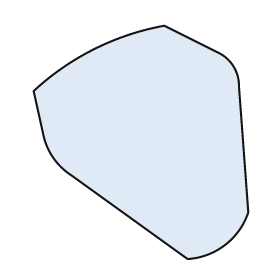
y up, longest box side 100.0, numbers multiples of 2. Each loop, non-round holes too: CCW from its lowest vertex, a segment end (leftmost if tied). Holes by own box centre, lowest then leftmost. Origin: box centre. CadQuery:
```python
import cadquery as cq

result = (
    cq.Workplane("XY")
    .moveTo(20.0, -50.0)
    .threePointArc((36.0, -44.0), (46.0, -30.0))
    .lineTo(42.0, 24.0)
    .threePointArc((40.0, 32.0), (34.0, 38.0))
    .lineTo(10.0, 50.0)
    .threePointArc((-20.0, 40.0), (-46.0, 22.0))
    .lineTo(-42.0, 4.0)
    .threePointArc((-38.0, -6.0), (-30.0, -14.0))
    .close()
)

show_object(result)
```